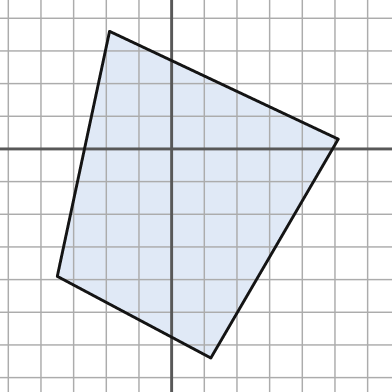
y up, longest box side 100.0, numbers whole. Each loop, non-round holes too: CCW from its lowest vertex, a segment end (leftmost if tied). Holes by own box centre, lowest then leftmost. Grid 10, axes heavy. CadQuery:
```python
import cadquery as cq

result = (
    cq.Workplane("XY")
    .moveTo(12.0, -64.0)
    .lineTo(51.0, 3.0)
    .lineTo(-19.0, 36.0)
    .lineTo(-35.0, -39.0)
    .close()
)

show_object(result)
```